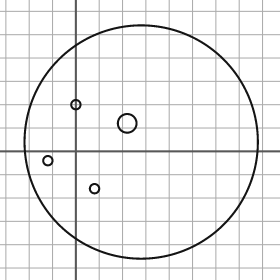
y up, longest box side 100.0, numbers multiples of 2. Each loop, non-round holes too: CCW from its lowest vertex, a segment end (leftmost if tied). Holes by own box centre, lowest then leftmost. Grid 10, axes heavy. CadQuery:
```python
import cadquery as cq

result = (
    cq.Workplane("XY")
    .moveTo(28.0, 4.0)
    .circle(50.0)
    .moveTo(8.0, -16.0)
    .circle(2.0)
    .moveTo(-12.0, -4.0)
    .circle(2.0)
    .moveTo(22.0, 12.0)
    .circle(4.0)
    .moveTo(0.0, 20.0)
    .circle(2.0)
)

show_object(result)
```